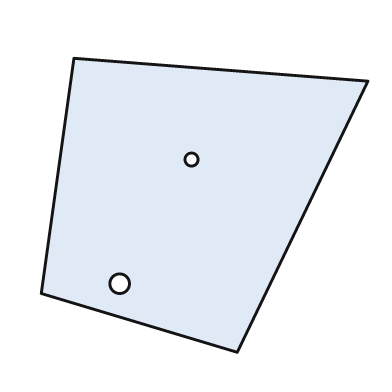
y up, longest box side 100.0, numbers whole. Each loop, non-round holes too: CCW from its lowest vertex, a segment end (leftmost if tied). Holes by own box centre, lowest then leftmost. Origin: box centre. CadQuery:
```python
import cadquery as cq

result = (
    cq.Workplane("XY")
    .moveTo(10.0, -45.0)
    .lineTo(50.0, 38.0)
    .lineTo(-40.0, 45.0)
    .lineTo(-50.0, -27.0)
    .close()
    .moveTo(-26.0, -24.0)
    .circle(3.0)
    .moveTo(-4.0, 14.0)
    .circle(2.0)
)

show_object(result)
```